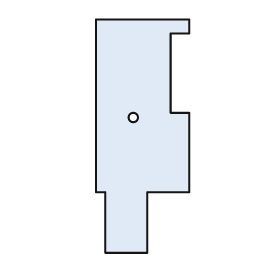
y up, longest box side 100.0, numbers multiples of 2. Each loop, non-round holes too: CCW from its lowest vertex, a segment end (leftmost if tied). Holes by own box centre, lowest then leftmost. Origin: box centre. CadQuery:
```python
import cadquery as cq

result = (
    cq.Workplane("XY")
    .moveTo(-16.0, -50.0)
    .lineTo(2.0, -50.0)
    .lineTo(2.0, -24.0)
    .lineTo(20.0, -24.0)
    .lineTo(20.0, 10.0)
    .lineTo(12.0, 10.0)
    .lineTo(12.0, 44.0)
    .lineTo(20.0, 44.0)
    .lineTo(20.0, 50.0)
    .lineTo(-20.0, 50.0)
    .lineTo(-20.0, -24.0)
    .lineTo(-16.0, -24.0)
    .close()
    .moveTo(-4.0, 8.0)
    .circle(2.0)
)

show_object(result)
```